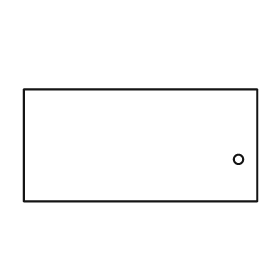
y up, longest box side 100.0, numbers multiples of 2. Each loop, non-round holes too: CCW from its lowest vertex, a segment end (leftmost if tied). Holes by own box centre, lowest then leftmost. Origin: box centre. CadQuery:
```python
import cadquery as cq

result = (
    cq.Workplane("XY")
    .moveTo(-50.0, -24.0)
    .lineTo(50.0, -24.0)
    .lineTo(50.0, 24.0)
    .lineTo(-50.0, 24.0)
    .close()
    .moveTo(42.0, -6.0)
    .circle(2.0)
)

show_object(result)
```